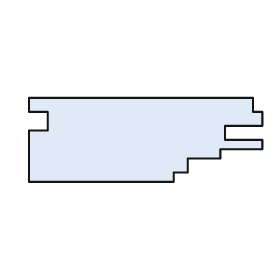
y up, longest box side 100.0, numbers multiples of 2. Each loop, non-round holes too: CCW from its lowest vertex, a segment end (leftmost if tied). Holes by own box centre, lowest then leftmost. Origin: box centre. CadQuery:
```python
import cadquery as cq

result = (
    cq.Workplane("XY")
    .moveTo(-50.0, -18.0)
    .lineTo(12.0, -18.0)
    .lineTo(12.0, -14.0)
    .lineTo(18.0, -14.0)
    .lineTo(18.0, -8.0)
    .lineTo(32.0, -8.0)
    .lineTo(32.0, -4.0)
    .lineTo(50.0, -4.0)
    .lineTo(50.0, 0.0)
    .lineTo(34.0, 0.0)
    .lineTo(34.0, 6.0)
    .lineTo(50.0, 6.0)
    .lineTo(50.0, 12.0)
    .lineTo(46.0, 12.0)
    .lineTo(46.0, 18.0)
    .lineTo(-50.0, 18.0)
    .lineTo(-50.0, 12.0)
    .lineTo(-42.0, 12.0)
    .lineTo(-42.0, 4.0)
    .lineTo(-50.0, 4.0)
    .close()
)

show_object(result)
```